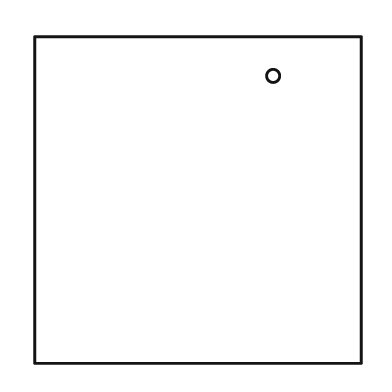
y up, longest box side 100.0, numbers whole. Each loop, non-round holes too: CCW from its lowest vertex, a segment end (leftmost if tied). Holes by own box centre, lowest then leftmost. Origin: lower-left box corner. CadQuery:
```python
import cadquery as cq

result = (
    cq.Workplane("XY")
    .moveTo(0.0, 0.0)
    .lineTo(100.0, 0.0)
    .lineTo(100.0, 100.0)
    .lineTo(0.0, 100.0)
    .close()
    .moveTo(73.0, 88.0)
    .circle(2.0)
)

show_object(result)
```